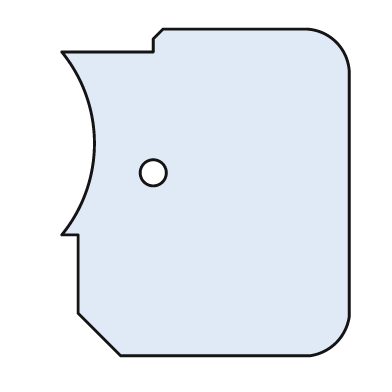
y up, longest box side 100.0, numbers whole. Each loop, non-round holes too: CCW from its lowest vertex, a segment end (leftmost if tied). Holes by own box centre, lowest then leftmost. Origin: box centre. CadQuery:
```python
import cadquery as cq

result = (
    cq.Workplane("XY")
    .moveTo(-26.0, -50.0)
    .lineTo(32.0, -50.0)
    .threePointArc((40.0, -46.0), (44.0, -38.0))
    .lineTo(44.0, 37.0)
    .threePointArc((40.0, 46.0), (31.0, 50.0))
    .lineTo(-13.0, 50.0)
    .lineTo(-16.0, 47.0)
    .lineTo(-16.0, 43.0)
    .lineTo(-44.0, 43.0)
    .threePointArc((-34.0, 15.0), (-44.0, -13.0))
    .lineTo(-39.0, -13.0)
    .lineTo(-39.0, -37.0)
    .close()
    .moveTo(-16.0, 6.0)
    .circle(4.0)
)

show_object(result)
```